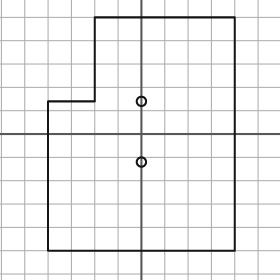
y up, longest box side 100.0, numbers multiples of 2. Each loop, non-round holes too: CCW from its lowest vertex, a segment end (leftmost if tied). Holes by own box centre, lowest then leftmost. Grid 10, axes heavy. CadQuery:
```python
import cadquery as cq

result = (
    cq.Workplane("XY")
    .moveTo(-40.0, -50.0)
    .lineTo(40.0, -50.0)
    .lineTo(40.0, 50.0)
    .lineTo(-20.0, 50.0)
    .lineTo(-20.0, 14.0)
    .lineTo(-40.0, 14.0)
    .close()
    .moveTo(0.0, -12.0)
    .circle(2.0)
    .moveTo(0.0, 14.0)
    .circle(2.0)
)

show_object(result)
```